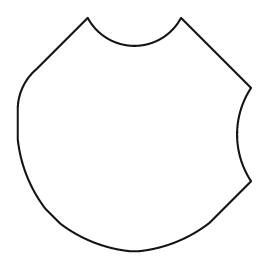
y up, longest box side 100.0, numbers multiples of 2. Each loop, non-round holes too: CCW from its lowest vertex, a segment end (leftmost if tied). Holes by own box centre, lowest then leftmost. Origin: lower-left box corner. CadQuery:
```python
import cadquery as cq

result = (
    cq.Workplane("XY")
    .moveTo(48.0, 0.0)
    .lineTo(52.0, 0.0)
    .threePointArc((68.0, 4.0), (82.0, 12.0))
    .lineTo(100.0, 30.0)
    .threePointArc((94.0, 50.0), (100.0, 70.0))
    .lineTo(70.0, 100.0)
    .threePointArc((50.0, 88.0), (30.0, 100.0))
    .lineTo(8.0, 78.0)
    .threePointArc((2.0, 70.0), (0.0, 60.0))
    .lineTo(0.0, 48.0)
    .threePointArc((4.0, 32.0), (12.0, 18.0))
    .lineTo(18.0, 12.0)
    .threePointArc((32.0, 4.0), (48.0, 0.0))
    .close()
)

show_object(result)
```